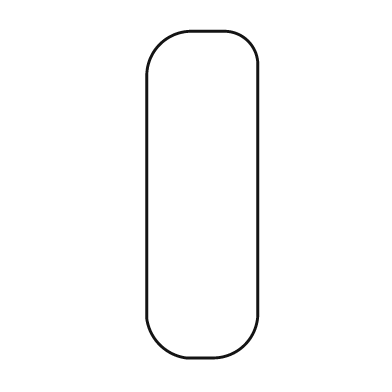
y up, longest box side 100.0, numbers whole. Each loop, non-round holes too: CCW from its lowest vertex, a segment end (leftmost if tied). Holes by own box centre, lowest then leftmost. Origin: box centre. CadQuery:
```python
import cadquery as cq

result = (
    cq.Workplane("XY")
    .moveTo(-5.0, -50.0)
    .lineTo(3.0, -50.0)
    .threePointArc((13.0, -46.0), (17.0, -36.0))
    .lineTo(17.0, 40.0)
    .threePointArc((14.0, 47.0), (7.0, 50.0))
    .lineTo(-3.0, 50.0)
    .threePointArc((-13.0, 46.0), (-17.0, 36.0))
    .lineTo(-17.0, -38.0)
    .threePointArc((-13.0, -46.0), (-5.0, -50.0))
    .close()
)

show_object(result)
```